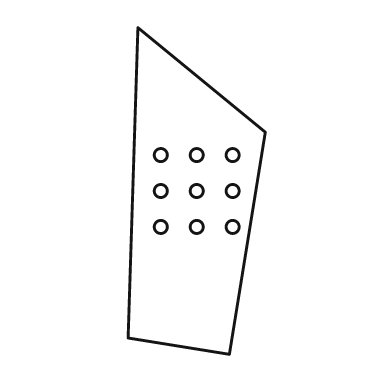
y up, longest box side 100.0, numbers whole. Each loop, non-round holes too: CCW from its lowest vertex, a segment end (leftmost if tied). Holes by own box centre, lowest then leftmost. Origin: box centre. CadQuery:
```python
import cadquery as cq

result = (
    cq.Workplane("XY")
    .moveTo(10.0, -50.0)
    .lineTo(21.0, 18.0)
    .lineTo(-18.0, 50.0)
    .lineTo(-21.0, -45.0)
    .close()
    .moveTo(-11.0, -11.0)
    .circle(2.0)
    .moveTo(0.0, -11.0)
    .circle(2.0)
    .moveTo(11.0, -11.0)
    .circle(2.0)
    .moveTo(-11.0, 0.0)
    .circle(2.0)
    .moveTo(0.0, 0.0)
    .circle(2.0)
    .moveTo(11.0, 0.0)
    .circle(2.0)
    .moveTo(-11.0, 11.0)
    .circle(2.0)
    .moveTo(0.0, 11.0)
    .circle(2.0)
    .moveTo(11.0, 11.0)
    .circle(2.0)
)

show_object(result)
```